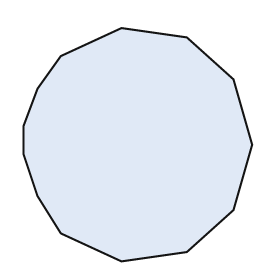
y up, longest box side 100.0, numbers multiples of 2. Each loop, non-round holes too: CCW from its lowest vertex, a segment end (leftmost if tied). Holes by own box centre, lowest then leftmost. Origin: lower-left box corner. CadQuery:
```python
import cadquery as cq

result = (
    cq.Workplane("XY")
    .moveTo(42.0, 0.0)
    .lineTo(70.0, 4.0)
    .lineTo(90.0, 22.0)
    .lineTo(98.0, 50.0)
    .lineTo(90.0, 78.0)
    .lineTo(70.0, 96.0)
    .lineTo(42.0, 100.0)
    .lineTo(16.0, 88.0)
    .lineTo(6.0, 74.0)
    .lineTo(0.0, 58.0)
    .lineTo(0.0, 46.0)
    .lineTo(6.0, 28.0)
    .lineTo(16.0, 12.0)
    .close()
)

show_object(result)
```